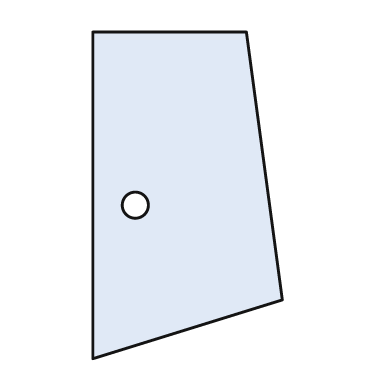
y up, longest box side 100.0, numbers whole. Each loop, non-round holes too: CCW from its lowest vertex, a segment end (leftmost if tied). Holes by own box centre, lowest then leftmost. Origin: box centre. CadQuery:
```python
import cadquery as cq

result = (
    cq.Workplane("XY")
    .moveTo(-29.0, -50.0)
    .lineTo(29.0, -32.0)
    .lineTo(18.0, 50.0)
    .lineTo(-29.0, 50.0)
    .close()
    .moveTo(-16.0, -3.0)
    .circle(4.0)
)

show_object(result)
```